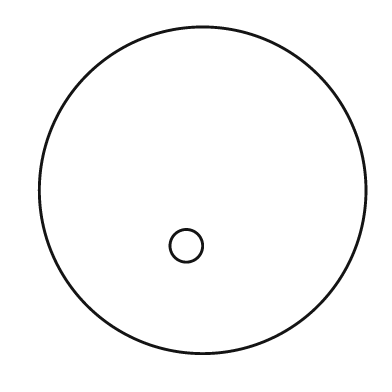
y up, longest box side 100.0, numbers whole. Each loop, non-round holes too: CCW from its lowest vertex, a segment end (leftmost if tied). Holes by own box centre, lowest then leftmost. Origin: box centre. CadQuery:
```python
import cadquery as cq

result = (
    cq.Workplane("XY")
    .moveTo(0.0, 0.0)
    .circle(50.0)
    .moveTo(-5.0, -17.0)
    .circle(5.0)
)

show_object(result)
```